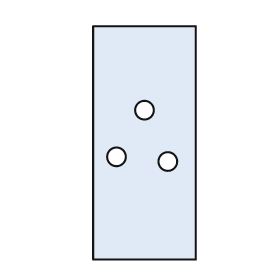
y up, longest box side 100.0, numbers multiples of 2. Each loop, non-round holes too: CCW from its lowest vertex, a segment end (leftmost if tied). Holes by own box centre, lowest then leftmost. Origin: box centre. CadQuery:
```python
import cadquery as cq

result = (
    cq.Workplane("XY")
    .moveTo(-22.0, -50.0)
    .lineTo(22.0, -50.0)
    .lineTo(22.0, 50.0)
    .lineTo(-22.0, 50.0)
    .close()
    .moveTo(10.0, -8.0)
    .circle(4.0)
    .moveTo(-12.0, -6.0)
    .circle(4.0)
    .moveTo(0.0, 14.0)
    .circle(4.0)
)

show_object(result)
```